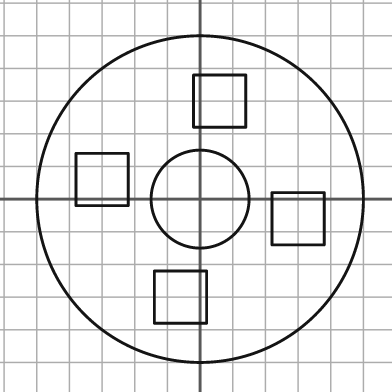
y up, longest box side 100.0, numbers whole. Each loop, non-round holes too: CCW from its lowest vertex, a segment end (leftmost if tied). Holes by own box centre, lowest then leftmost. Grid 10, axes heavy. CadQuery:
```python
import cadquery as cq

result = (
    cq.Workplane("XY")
    .moveTo(0.0, 0.0)
    .circle(50.0)
    .moveTo(-14.0, -38.0)
    .lineTo(2.0, -38.0)
    .lineTo(2.0, -22.0)
    .lineTo(-14.0, -22.0)
    .close()
    .moveTo(22.0, -14.0)
    .lineTo(38.0, -14.0)
    .lineTo(38.0, 2.0)
    .lineTo(22.0, 2.0)
    .close()
    .moveTo(0.0, 0.0)
    .circle(15.0)
    .moveTo(-38.0, -2.0)
    .lineTo(-22.0, -2.0)
    .lineTo(-22.0, 14.0)
    .lineTo(-38.0, 14.0)
    .close()
    .moveTo(-2.0, 22.0)
    .lineTo(14.0, 22.0)
    .lineTo(14.0, 38.0)
    .lineTo(-2.0, 38.0)
    .close()
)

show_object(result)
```